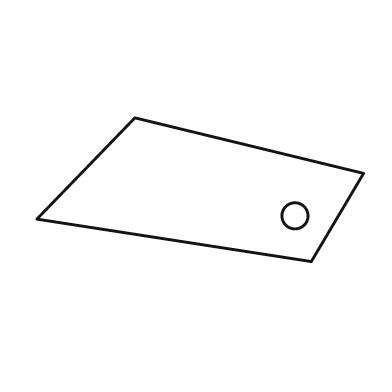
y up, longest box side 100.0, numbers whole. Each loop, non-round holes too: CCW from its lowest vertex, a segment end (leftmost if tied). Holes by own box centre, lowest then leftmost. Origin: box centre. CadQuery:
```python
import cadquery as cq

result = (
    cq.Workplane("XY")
    .moveTo(34.0, -22.0)
    .lineTo(50.0, 5.0)
    .lineTo(-20.0, 22.0)
    .lineTo(-50.0, -9.0)
    .close()
    .moveTo(29.0, -8.0)
    .circle(4.0)
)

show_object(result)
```